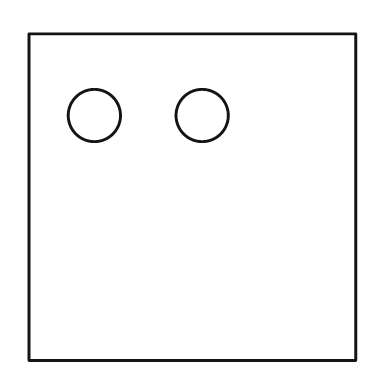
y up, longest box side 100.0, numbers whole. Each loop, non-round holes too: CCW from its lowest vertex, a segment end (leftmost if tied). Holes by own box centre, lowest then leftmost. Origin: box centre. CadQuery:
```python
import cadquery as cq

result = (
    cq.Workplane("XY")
    .moveTo(-50.0, -50.0)
    .lineTo(50.0, -50.0)
    .lineTo(50.0, 50.0)
    .lineTo(-50.0, 50.0)
    .close()
    .moveTo(-30.0, 25.0)
    .circle(8.0)
    .moveTo(3.0, 25.0)
    .circle(8.0)
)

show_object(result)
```